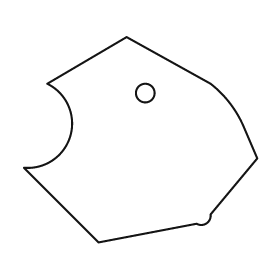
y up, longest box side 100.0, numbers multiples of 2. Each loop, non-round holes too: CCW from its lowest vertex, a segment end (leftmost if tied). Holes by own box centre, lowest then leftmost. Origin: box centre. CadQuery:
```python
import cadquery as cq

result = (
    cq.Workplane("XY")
    .moveTo(-18.0, -44.0)
    .lineTo(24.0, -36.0)
    .threePointArc((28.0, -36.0), (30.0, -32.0))
    .lineTo(50.0, -8.0)
    .lineTo(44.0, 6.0)
    .threePointArc((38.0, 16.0), (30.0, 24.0))
    .lineTo(-6.0, 44.0)
    .lineTo(-40.0, 24.0)
    .threePointArc((-30.0, 2.0), (-50.0, -12.0))
    .close()
    .moveTo(2.0, 20.0)
    .circle(4.0)
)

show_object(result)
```